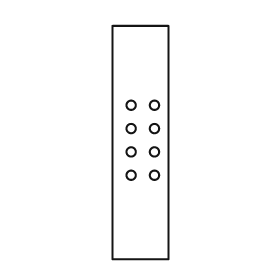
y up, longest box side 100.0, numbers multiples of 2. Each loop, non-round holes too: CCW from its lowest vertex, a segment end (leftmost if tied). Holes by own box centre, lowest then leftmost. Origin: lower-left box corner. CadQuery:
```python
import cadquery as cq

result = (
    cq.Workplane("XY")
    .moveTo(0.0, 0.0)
    .lineTo(24.0, 0.0)
    .lineTo(24.0, 100.0)
    .lineTo(0.0, 100.0)
    .close()
    .moveTo(8.0, 36.0)
    .circle(2.0)
    .moveTo(18.0, 36.0)
    .circle(2.0)
    .moveTo(8.0, 46.0)
    .circle(2.0)
    .moveTo(18.0, 46.0)
    .circle(2.0)
    .moveTo(8.0, 56.0)
    .circle(2.0)
    .moveTo(18.0, 56.0)
    .circle(2.0)
    .moveTo(8.0, 66.0)
    .circle(2.0)
    .moveTo(18.0, 66.0)
    .circle(2.0)
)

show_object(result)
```